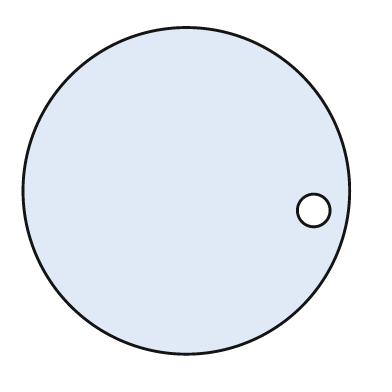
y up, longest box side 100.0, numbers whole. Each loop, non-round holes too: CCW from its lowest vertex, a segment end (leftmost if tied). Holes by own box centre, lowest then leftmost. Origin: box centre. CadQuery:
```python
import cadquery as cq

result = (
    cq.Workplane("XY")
    .moveTo(0.0, 0.0)
    .circle(50.0)
    .moveTo(39.0, -6.0)
    .circle(5.0)
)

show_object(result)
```